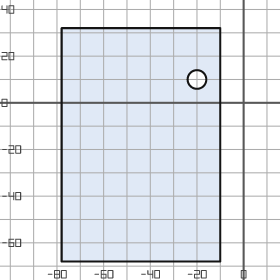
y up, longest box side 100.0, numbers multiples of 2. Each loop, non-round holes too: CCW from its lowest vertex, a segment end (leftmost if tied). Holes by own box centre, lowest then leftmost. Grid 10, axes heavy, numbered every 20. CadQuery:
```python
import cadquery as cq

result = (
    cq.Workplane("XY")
    .moveTo(-78.0, -68.0)
    .lineTo(-10.0, -68.0)
    .lineTo(-10.0, 32.0)
    .lineTo(-78.0, 32.0)
    .close()
    .moveTo(-20.0, 10.0)
    .circle(4.0)
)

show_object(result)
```